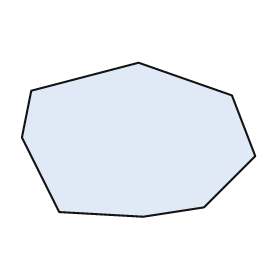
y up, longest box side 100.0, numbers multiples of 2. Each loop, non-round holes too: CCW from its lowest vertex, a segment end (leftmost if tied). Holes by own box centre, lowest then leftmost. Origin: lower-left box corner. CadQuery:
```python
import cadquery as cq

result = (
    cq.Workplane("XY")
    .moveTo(52.0, 0.0)
    .lineTo(78.0, 4.0)
    .lineTo(100.0, 26.0)
    .lineTo(90.0, 52.0)
    .lineTo(50.0, 66.0)
    .lineTo(4.0, 54.0)
    .lineTo(0.0, 34.0)
    .lineTo(16.0, 2.0)
    .close()
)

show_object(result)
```